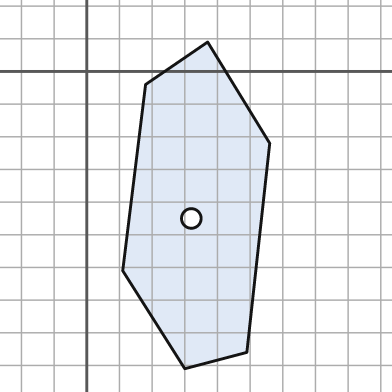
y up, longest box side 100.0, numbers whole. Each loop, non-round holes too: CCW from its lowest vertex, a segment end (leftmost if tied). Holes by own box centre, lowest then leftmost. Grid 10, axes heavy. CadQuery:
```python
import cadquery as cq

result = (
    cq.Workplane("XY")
    .moveTo(30.0, -91.0)
    .lineTo(49.0, -86.0)
    .lineTo(56.0, -22.0)
    .lineTo(37.0, 9.0)
    .lineTo(18.0, -4.0)
    .lineTo(11.0, -61.0)
    .close()
    .moveTo(32.0, -45.0)
    .circle(3.0)
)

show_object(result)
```